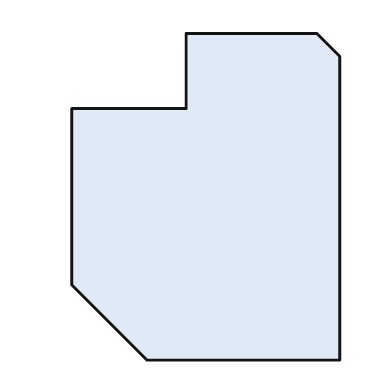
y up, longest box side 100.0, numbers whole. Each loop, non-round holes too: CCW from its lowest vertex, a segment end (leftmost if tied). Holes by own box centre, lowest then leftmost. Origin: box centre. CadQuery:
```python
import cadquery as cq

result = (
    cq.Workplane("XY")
    .moveTo(-18.0, -50.0)
    .lineTo(41.0, -50.0)
    .lineTo(41.0, 43.0)
    .lineTo(34.0, 50.0)
    .lineTo(-6.0, 50.0)
    .lineTo(-6.0, 27.0)
    .lineTo(-41.0, 27.0)
    .lineTo(-41.0, -27.0)
    .close()
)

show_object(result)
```